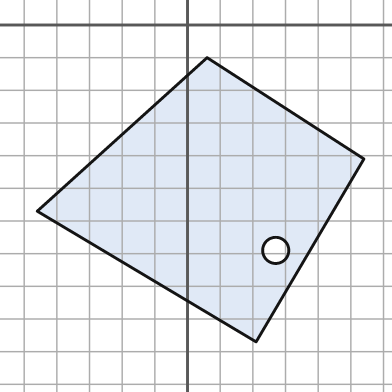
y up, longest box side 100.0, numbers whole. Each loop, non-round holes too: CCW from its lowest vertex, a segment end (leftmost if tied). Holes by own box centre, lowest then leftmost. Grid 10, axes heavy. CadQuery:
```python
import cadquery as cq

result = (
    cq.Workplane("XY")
    .moveTo(21.0, -97.0)
    .lineTo(54.0, -41.0)
    .lineTo(6.0, -10.0)
    .lineTo(-46.0, -57.0)
    .close()
    .moveTo(27.0, -69.0)
    .circle(4.0)
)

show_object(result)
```